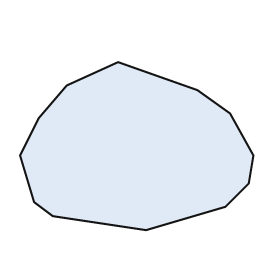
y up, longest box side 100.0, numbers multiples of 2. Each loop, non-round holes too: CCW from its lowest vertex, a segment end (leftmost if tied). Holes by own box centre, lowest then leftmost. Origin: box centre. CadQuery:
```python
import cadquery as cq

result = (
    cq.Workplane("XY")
    .moveTo(4.0, -36.0)
    .lineTo(38.0, -26.0)
    .lineTo(48.0, -16.0)
    .lineTo(50.0, -4.0)
    .lineTo(40.0, 14.0)
    .lineTo(26.0, 24.0)
    .lineTo(-8.0, 36.0)
    .lineTo(-30.0, 26.0)
    .lineTo(-42.0, 12.0)
    .lineTo(-50.0, -4.0)
    .lineTo(-44.0, -24.0)
    .lineTo(-36.0, -30.0)
    .close()
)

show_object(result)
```